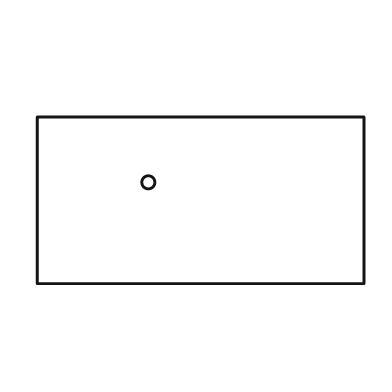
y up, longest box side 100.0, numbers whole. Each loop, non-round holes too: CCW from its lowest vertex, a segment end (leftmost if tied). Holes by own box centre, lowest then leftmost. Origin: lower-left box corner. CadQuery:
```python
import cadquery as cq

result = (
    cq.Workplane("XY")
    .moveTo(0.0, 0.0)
    .lineTo(100.0, 0.0)
    .lineTo(100.0, 51.0)
    .lineTo(0.0, 51.0)
    .close()
    .moveTo(34.0, 31.0)
    .circle(2.0)
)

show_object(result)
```